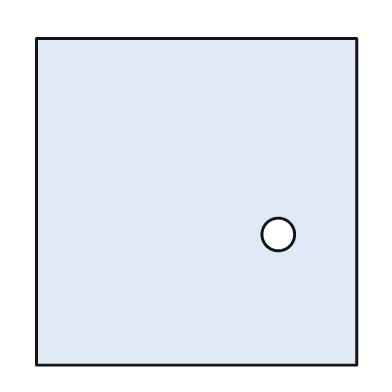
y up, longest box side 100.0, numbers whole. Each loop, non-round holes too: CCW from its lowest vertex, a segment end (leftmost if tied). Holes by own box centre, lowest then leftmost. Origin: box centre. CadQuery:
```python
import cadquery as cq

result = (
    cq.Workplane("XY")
    .moveTo(-49.0, -50.0)
    .lineTo(49.0, -50.0)
    .lineTo(49.0, 50.0)
    .lineTo(-49.0, 50.0)
    .close()
    .moveTo(25.0, -10.0)
    .circle(5.0)
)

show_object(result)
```